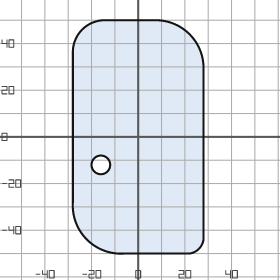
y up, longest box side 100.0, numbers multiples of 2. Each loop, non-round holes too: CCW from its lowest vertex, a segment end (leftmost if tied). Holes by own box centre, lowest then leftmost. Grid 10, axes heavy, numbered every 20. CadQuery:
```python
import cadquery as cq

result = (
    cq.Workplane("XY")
    .moveTo(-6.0, -50.0)
    .lineTo(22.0, -50.0)
    .threePointArc((26.0, -48.0), (28.0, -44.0))
    .lineTo(28.0, 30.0)
    .threePointArc((22.0, 44.0), (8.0, 50.0))
    .lineTo(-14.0, 50.0)
    .threePointArc((-24.0, 46.0), (-28.0, 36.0))
    .lineTo(-28.0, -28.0)
    .threePointArc((-22.0, -44.0), (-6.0, -50.0))
    .close()
    .moveTo(-16.0, -12.0)
    .circle(4.0)
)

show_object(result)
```